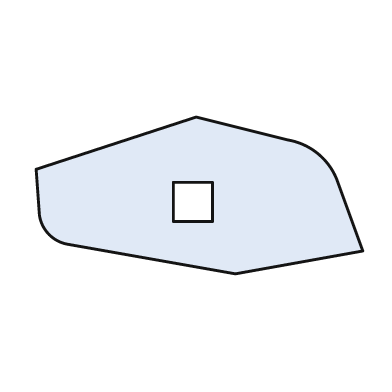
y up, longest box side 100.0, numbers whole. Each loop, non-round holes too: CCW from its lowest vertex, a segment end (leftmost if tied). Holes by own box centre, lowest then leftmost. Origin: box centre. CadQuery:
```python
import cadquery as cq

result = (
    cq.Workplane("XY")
    .moveTo(11.0, -24.0)
    .lineTo(50.0, -17.0)
    .lineTo(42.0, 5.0)
    .threePointArc((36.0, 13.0), (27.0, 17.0))
    .lineTo(-1.0, 24.0)
    .lineTo(-50.0, 8.0)
    .lineTo(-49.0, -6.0)
    .threePointArc((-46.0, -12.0), (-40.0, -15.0))
    .close()
    .moveTo(-8.0, -8.0)
    .lineTo(4.0, -8.0)
    .lineTo(4.0, 4.0)
    .lineTo(-8.0, 4.0)
    .close()
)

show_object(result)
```